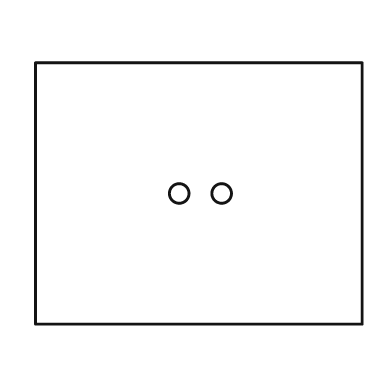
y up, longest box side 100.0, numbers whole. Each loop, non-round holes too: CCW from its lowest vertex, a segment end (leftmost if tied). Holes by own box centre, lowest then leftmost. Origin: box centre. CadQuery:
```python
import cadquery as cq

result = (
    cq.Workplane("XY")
    .moveTo(-50.0, -40.0)
    .lineTo(50.0, -40.0)
    .lineTo(50.0, 40.0)
    .lineTo(-50.0, 40.0)
    .close()
    .moveTo(-6.0, 0.0)
    .circle(3.0)
    .moveTo(7.0, 0.0)
    .circle(3.0)
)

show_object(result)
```